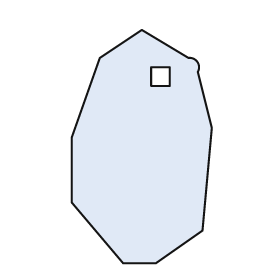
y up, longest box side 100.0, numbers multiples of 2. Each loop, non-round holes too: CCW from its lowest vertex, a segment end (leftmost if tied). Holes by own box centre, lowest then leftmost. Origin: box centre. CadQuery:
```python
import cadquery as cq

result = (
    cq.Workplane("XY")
    .moveTo(-8.0, -50.0)
    .lineTo(6.0, -50.0)
    .lineTo(26.0, -36.0)
    .lineTo(30.0, 8.0)
    .lineTo(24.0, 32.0)
    .threePointArc((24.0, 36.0), (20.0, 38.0))
    .lineTo(0.0, 50.0)
    .lineTo(-18.0, 38.0)
    .lineTo(-30.0, 4.0)
    .lineTo(-30.0, -24.0)
    .close()
    .moveTo(4.0, 26.0)
    .lineTo(12.0, 26.0)
    .lineTo(12.0, 34.0)
    .lineTo(4.0, 34.0)
    .close()
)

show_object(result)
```